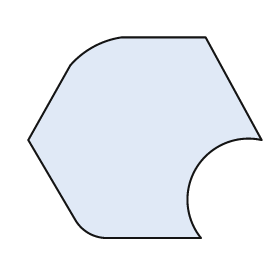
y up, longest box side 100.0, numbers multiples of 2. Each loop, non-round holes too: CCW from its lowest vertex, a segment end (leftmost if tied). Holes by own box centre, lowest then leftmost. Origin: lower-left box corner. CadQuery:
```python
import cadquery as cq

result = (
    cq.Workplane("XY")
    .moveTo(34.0, 0.0)
    .lineTo(74.0, 0.0)
    .threePointArc((72.0, 30.0), (100.0, 42.0))
    .lineTo(76.0, 86.0)
    .lineTo(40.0, 86.0)
    .threePointArc((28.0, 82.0), (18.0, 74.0))
    .lineTo(0.0, 42.0)
    .lineTo(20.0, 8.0)
    .threePointArc((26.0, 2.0), (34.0, 0.0))
    .close()
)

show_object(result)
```